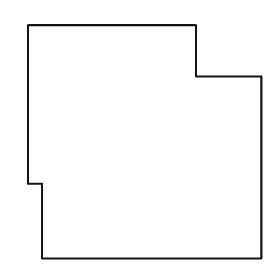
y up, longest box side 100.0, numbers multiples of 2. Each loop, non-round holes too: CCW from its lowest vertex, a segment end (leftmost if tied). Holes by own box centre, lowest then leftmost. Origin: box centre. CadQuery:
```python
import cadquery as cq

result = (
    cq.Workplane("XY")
    .moveTo(-44.0, -50.0)
    .lineTo(50.0, -50.0)
    .lineTo(50.0, 28.0)
    .lineTo(22.0, 28.0)
    .lineTo(22.0, 50.0)
    .lineTo(-50.0, 50.0)
    .lineTo(-50.0, -18.0)
    .lineTo(-44.0, -18.0)
    .close()
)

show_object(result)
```